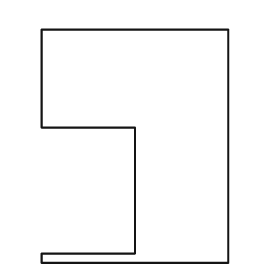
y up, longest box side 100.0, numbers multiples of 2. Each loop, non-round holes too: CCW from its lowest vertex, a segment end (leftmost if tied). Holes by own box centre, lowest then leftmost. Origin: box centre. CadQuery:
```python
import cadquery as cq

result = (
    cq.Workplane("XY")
    .moveTo(-40.0, -50.0)
    .lineTo(40.0, -50.0)
    .lineTo(40.0, 50.0)
    .lineTo(-40.0, 50.0)
    .lineTo(-40.0, 8.0)
    .lineTo(0.0, 8.0)
    .lineTo(0.0, -46.0)
    .lineTo(-40.0, -46.0)
    .close()
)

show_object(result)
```